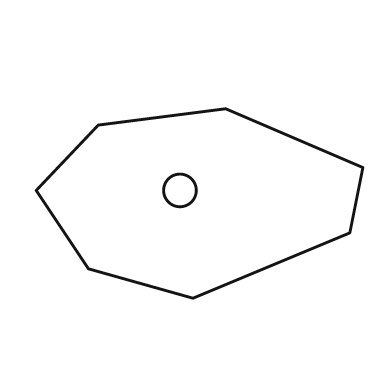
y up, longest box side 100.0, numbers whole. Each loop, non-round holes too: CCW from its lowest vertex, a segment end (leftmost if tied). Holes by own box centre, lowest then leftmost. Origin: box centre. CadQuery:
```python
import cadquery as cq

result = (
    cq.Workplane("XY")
    .moveTo(-2.0, -29.0)
    .lineTo(46.0, -9.0)
    .lineTo(50.0, 11.0)
    .lineTo(8.0, 29.0)
    .lineTo(-31.0, 24.0)
    .lineTo(-50.0, 4.0)
    .lineTo(-34.0, -20.0)
    .close()
    .moveTo(-6.0, 4.0)
    .circle(5.0)
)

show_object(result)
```